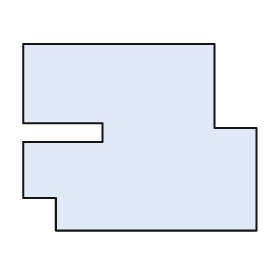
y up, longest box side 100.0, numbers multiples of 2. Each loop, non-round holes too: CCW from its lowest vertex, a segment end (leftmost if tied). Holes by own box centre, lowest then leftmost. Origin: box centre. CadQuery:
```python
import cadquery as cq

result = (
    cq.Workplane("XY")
    .moveTo(-36.0, -40.0)
    .lineTo(50.0, -40.0)
    .lineTo(50.0, 4.0)
    .lineTo(32.0, 4.0)
    .lineTo(32.0, 40.0)
    .lineTo(-50.0, 40.0)
    .lineTo(-50.0, 6.0)
    .lineTo(-16.0, 6.0)
    .lineTo(-16.0, -2.0)
    .lineTo(-50.0, -2.0)
    .lineTo(-50.0, -26.0)
    .lineTo(-36.0, -26.0)
    .close()
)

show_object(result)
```